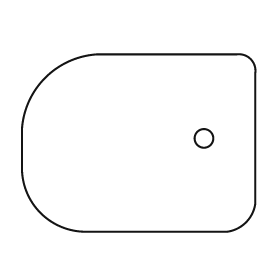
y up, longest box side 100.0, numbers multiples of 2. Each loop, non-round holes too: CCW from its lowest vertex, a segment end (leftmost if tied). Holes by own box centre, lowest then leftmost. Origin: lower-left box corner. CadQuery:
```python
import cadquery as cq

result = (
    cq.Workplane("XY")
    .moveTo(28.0, 0.0)
    .lineTo(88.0, 0.0)
    .threePointArc((96.0, 4.0), (100.0, 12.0))
    .lineTo(100.0, 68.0)
    .threePointArc((98.0, 74.0), (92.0, 76.0))
    .lineTo(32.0, 76.0)
    .threePointArc((10.0, 66.0), (0.0, 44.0))
    .lineTo(0.0, 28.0)
    .threePointArc((8.0, 8.0), (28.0, 0.0))
    .close()
    .moveTo(78.0, 40.0)
    .circle(4.0)
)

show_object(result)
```